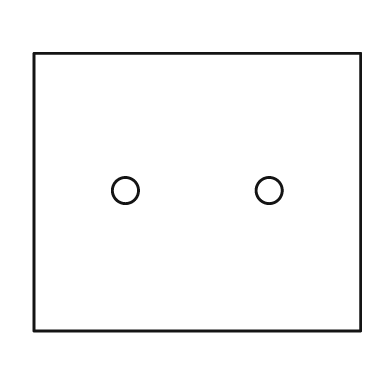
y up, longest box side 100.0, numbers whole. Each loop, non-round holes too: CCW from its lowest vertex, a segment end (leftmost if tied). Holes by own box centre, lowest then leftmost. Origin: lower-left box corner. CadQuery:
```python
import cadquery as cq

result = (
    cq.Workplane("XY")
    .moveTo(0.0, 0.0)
    .lineTo(100.0, 0.0)
    .lineTo(100.0, 85.0)
    .lineTo(0.0, 85.0)
    .close()
    .moveTo(28.0, 43.0)
    .circle(4.0)
    .moveTo(72.0, 43.0)
    .circle(4.0)
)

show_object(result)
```